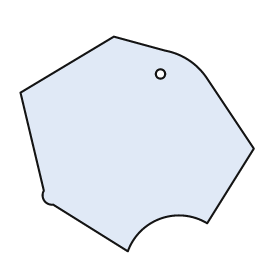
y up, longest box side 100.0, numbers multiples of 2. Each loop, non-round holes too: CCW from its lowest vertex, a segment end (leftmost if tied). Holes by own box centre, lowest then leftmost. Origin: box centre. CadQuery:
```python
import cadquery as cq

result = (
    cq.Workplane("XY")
    .moveTo(-4.0, -46.0)
    .threePointArc((10.0, -32.0), (30.0, -34.0))
    .lineTo(50.0, -2.0)
    .lineTo(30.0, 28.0)
    .threePointArc((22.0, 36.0), (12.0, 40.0))
    .lineTo(-10.0, 46.0)
    .lineTo(-50.0, 22.0)
    .lineTo(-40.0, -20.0)
    .threePointArc((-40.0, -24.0), (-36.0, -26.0))
    .close()
    .moveTo(10.0, 30.0)
    .circle(2.0)
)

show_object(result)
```